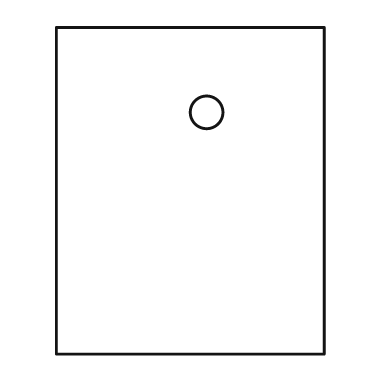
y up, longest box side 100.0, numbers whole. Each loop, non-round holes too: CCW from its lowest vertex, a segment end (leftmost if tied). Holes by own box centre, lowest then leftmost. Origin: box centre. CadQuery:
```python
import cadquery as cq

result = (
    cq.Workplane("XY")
    .moveTo(-41.0, -50.0)
    .lineTo(41.0, -50.0)
    .lineTo(41.0, 50.0)
    .lineTo(-41.0, 50.0)
    .close()
    .moveTo(5.0, 24.0)
    .circle(5.0)
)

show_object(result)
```